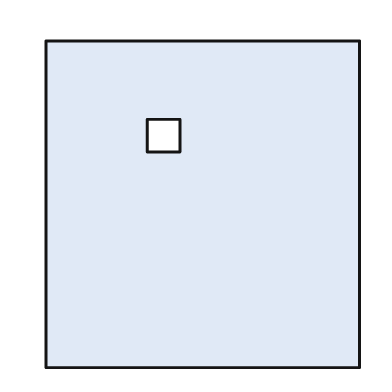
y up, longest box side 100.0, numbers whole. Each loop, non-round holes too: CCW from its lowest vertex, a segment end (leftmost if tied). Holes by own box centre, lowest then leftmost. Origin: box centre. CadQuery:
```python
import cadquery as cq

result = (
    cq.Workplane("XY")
    .moveTo(-48.0, -50.0)
    .lineTo(48.0, -50.0)
    .lineTo(48.0, 50.0)
    .lineTo(-48.0, 50.0)
    .close()
    .moveTo(-17.0, 16.0)
    .lineTo(-7.0, 16.0)
    .lineTo(-7.0, 26.0)
    .lineTo(-17.0, 26.0)
    .close()
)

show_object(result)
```